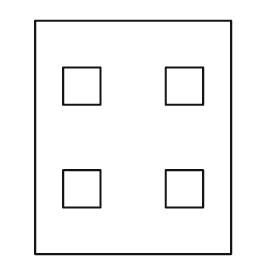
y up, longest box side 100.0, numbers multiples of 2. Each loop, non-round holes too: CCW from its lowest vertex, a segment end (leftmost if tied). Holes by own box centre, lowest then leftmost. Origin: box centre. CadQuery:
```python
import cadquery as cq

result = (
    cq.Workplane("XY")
    .moveTo(-42.0, -50.0)
    .lineTo(42.0, -50.0)
    .lineTo(42.0, 50.0)
    .lineTo(-42.0, 50.0)
    .close()
    .moveTo(-30.0, -30.0)
    .lineTo(-14.0, -30.0)
    .lineTo(-14.0, -14.0)
    .lineTo(-30.0, -14.0)
    .close()
    .moveTo(14.0, -30.0)
    .lineTo(30.0, -30.0)
    .lineTo(30.0, -14.0)
    .lineTo(14.0, -14.0)
    .close()
    .moveTo(-30.0, 14.0)
    .lineTo(-14.0, 14.0)
    .lineTo(-14.0, 30.0)
    .lineTo(-30.0, 30.0)
    .close()
    .moveTo(14.0, 14.0)
    .lineTo(30.0, 14.0)
    .lineTo(30.0, 30.0)
    .lineTo(14.0, 30.0)
    .close()
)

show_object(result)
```